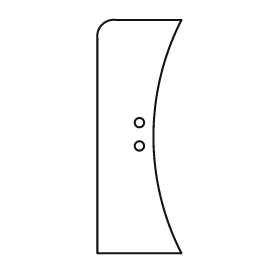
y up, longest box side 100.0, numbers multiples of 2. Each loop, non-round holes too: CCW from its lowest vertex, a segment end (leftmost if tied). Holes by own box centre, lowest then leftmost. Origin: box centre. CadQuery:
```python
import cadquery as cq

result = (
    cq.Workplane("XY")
    .moveTo(-18.0, -50.0)
    .lineTo(18.0, -50.0)
    .threePointArc((6.0, 0.0), (18.0, 50.0))
    .lineTo(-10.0, 50.0)
    .threePointArc((-16.0, 48.0), (-18.0, 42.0))
    .close()
    .moveTo(0.0, -4.0)
    .circle(2.0)
    .moveTo(0.0, 6.0)
    .circle(2.0)
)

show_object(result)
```